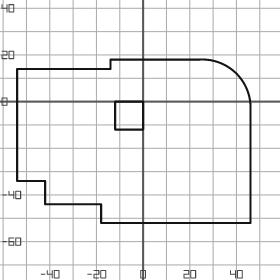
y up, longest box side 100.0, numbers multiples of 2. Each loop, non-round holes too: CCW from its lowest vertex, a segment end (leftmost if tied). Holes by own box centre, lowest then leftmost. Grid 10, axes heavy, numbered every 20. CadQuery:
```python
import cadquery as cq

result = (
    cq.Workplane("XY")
    .moveTo(-18.0, -52.0)
    .lineTo(46.0, -52.0)
    .lineTo(46.0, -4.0)
    .threePointArc((40.0, 12.0), (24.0, 18.0))
    .lineTo(-14.0, 18.0)
    .lineTo(-14.0, 14.0)
    .lineTo(-54.0, 14.0)
    .lineTo(-54.0, -34.0)
    .lineTo(-42.0, -34.0)
    .lineTo(-42.0, -44.0)
    .lineTo(-18.0, -44.0)
    .close()
    .moveTo(-12.0, -12.0)
    .lineTo(0.0, -12.0)
    .lineTo(0.0, 0.0)
    .lineTo(-12.0, 0.0)
    .close()
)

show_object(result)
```